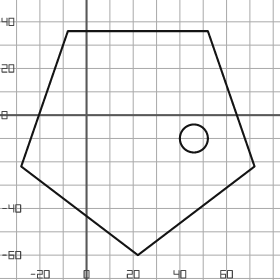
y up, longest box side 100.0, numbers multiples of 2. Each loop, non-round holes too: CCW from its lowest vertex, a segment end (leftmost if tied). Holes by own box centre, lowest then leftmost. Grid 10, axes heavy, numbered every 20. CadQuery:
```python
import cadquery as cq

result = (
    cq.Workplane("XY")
    .moveTo(22.0, -60.0)
    .lineTo(72.0, -22.0)
    .lineTo(52.0, 36.0)
    .lineTo(-8.0, 36.0)
    .lineTo(-28.0, -22.0)
    .close()
    .moveTo(46.0, -10.0)
    .circle(6.0)
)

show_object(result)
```